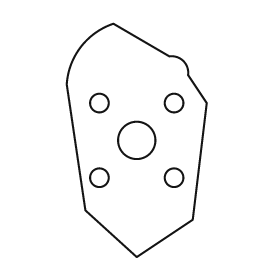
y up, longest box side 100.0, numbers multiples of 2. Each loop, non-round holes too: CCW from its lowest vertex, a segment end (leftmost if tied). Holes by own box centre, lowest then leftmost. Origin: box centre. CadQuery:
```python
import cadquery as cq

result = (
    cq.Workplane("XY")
    .moveTo(0.0, -50.0)
    .lineTo(24.0, -34.0)
    .lineTo(30.0, 16.0)
    .lineTo(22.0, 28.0)
    .threePointArc((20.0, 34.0), (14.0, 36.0))
    .lineTo(-10.0, 50.0)
    .threePointArc((-24.0, 40.0), (-30.0, 24.0))
    .lineTo(-22.0, -30.0)
    .close()
    .moveTo(-16.0, -16.0)
    .circle(4.0)
    .moveTo(16.0, -16.0)
    .circle(4.0)
    .moveTo(0.0, 0.0)
    .circle(8.0)
    .moveTo(-16.0, 16.0)
    .circle(4.0)
    .moveTo(16.0, 16.0)
    .circle(4.0)
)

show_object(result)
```